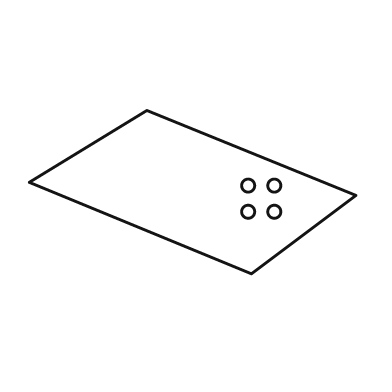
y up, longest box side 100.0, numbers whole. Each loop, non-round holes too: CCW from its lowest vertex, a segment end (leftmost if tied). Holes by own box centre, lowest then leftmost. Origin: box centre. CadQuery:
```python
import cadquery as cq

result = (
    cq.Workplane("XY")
    .moveTo(18.0, -25.0)
    .lineTo(50.0, -1.0)
    .lineTo(-14.0, 25.0)
    .lineTo(-50.0, 3.0)
    .close()
    .moveTo(17.0, -6.0)
    .circle(2.0)
    .moveTo(25.0, -6.0)
    .circle(2.0)
    .moveTo(17.0, 2.0)
    .circle(2.0)
    .moveTo(25.0, 2.0)
    .circle(2.0)
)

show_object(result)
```